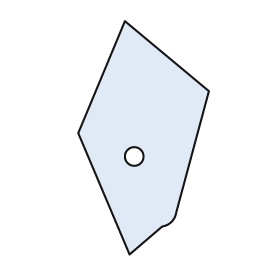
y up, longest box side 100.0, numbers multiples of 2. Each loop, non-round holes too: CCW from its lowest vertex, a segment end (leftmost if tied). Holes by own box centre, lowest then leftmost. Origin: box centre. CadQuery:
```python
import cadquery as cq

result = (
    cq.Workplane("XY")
    .moveTo(-6.0, -50.0)
    .lineTo(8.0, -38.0)
    .threePointArc((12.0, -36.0), (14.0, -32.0))
    .lineTo(28.0, 20.0)
    .lineTo(-8.0, 50.0)
    .lineTo(-28.0, 2.0)
    .close()
    .moveTo(-4.0, -8.0)
    .circle(4.0)
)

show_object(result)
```